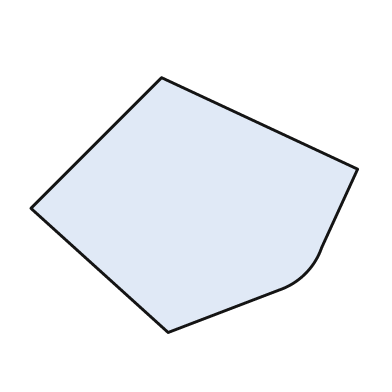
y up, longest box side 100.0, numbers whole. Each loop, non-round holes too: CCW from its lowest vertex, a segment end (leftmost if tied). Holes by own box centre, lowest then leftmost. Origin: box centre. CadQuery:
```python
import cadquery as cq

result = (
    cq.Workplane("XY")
    .moveTo(-8.0, -39.0)
    .lineTo(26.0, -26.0)
    .threePointArc((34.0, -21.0), (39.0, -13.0))
    .lineTo(50.0, 11.0)
    .lineTo(-10.0, 39.0)
    .lineTo(-50.0, -1.0)
    .close()
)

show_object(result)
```